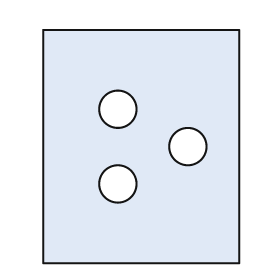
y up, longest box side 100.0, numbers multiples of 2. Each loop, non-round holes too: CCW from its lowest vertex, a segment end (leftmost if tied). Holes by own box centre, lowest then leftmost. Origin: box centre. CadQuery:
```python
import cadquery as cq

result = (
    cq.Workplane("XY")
    .moveTo(-42.0, -50.0)
    .lineTo(42.0, -50.0)
    .lineTo(42.0, 50.0)
    .lineTo(-42.0, 50.0)
    .close()
    .moveTo(-10.0, -16.0)
    .circle(8.0)
    .moveTo(20.0, 0.0)
    .circle(8.0)
    .moveTo(-10.0, 16.0)
    .circle(8.0)
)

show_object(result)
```